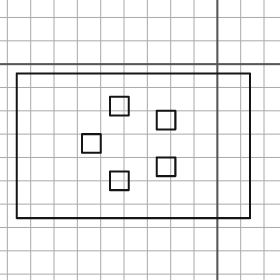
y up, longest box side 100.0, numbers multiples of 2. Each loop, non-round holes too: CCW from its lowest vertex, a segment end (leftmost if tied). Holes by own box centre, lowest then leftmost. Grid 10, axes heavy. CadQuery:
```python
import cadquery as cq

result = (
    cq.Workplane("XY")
    .moveTo(-86.0, -66.0)
    .lineTo(14.0, -66.0)
    .lineTo(14.0, -4.0)
    .lineTo(-86.0, -4.0)
    .close()
    .moveTo(-46.0, -54.0)
    .lineTo(-38.0, -54.0)
    .lineTo(-38.0, -46.0)
    .lineTo(-46.0, -46.0)
    .close()
    .moveTo(-26.0, -48.0)
    .lineTo(-18.0, -48.0)
    .lineTo(-18.0, -40.0)
    .lineTo(-26.0, -40.0)
    .close()
    .moveTo(-58.0, -38.0)
    .lineTo(-50.0, -38.0)
    .lineTo(-50.0, -30.0)
    .lineTo(-58.0, -30.0)
    .close()
    .moveTo(-26.0, -28.0)
    .lineTo(-18.0, -28.0)
    .lineTo(-18.0, -20.0)
    .lineTo(-26.0, -20.0)
    .close()
    .moveTo(-46.0, -22.0)
    .lineTo(-38.0, -22.0)
    .lineTo(-38.0, -14.0)
    .lineTo(-46.0, -14.0)
    .close()
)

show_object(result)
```